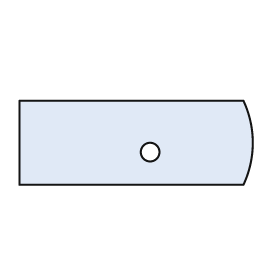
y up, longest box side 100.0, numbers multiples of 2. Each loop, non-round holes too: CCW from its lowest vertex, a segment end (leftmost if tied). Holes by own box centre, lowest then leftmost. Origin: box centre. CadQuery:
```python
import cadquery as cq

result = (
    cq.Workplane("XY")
    .moveTo(-50.0, -18.0)
    .lineTo(46.0, -18.0)
    .threePointArc((50.0, 0.0), (46.0, 18.0))
    .lineTo(-50.0, 18.0)
    .close()
    .moveTo(6.0, -4.0)
    .circle(4.0)
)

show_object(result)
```